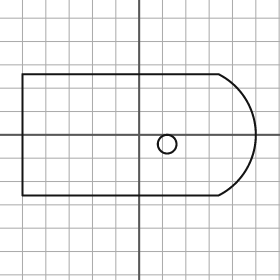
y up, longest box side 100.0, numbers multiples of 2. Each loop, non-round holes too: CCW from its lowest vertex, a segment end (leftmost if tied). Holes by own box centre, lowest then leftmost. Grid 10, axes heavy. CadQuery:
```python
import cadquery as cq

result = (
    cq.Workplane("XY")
    .moveTo(-50.0, -26.0)
    .lineTo(34.0, -26.0)
    .threePointArc((50.0, 0.0), (34.0, 26.0))
    .lineTo(-50.0, 26.0)
    .close()
    .moveTo(12.0, -4.0)
    .circle(4.0)
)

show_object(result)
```